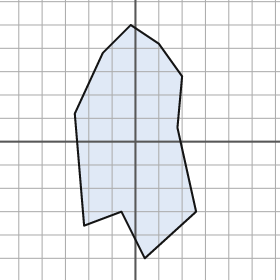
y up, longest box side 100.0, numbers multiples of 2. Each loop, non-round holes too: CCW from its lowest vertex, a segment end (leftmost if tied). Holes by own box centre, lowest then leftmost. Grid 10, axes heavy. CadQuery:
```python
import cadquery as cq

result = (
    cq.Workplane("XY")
    .moveTo(4.0, -50.0)
    .lineTo(26.0, -30.0)
    .lineTo(18.0, 6.0)
    .lineTo(20.0, 28.0)
    .lineTo(10.0, 42.0)
    .lineTo(-2.0, 50.0)
    .lineTo(-14.0, 38.0)
    .lineTo(-26.0, 12.0)
    .lineTo(-22.0, -36.0)
    .lineTo(-6.0, -30.0)
    .close()
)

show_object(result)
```